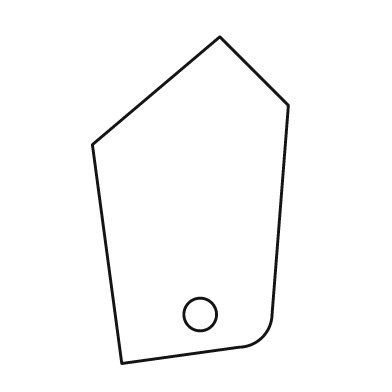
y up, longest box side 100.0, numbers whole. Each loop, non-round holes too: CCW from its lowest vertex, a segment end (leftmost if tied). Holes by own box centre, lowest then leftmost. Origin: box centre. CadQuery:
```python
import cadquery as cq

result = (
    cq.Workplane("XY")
    .moveTo(-21.0, -50.0)
    .lineTo(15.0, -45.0)
    .threePointArc((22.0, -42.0), (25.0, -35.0))
    .lineTo(30.0, 29.0)
    .lineTo(9.0, 50.0)
    .lineTo(-30.0, 17.0)
    .close()
    .moveTo(3.0, -35.0)
    .circle(5.0)
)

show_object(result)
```